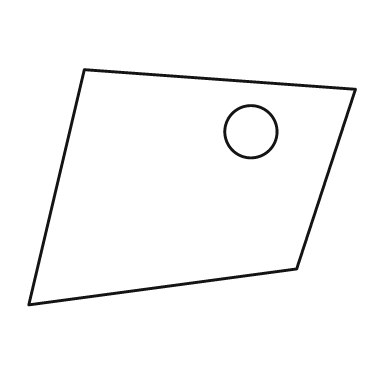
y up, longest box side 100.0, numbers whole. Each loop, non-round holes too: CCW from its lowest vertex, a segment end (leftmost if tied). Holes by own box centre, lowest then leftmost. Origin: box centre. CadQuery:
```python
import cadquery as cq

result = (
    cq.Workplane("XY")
    .moveTo(-50.0, -36.0)
    .lineTo(32.0, -25.0)
    .lineTo(50.0, 30.0)
    .lineTo(-33.0, 36.0)
    .close()
    .moveTo(18.0, 17.0)
    .circle(8.0)
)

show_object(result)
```